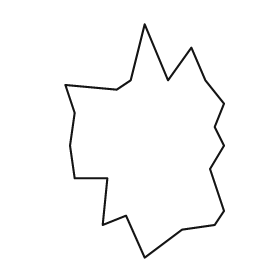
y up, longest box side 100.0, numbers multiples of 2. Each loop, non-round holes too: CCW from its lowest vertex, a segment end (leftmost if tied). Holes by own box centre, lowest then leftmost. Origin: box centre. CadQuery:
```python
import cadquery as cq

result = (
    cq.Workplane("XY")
    .moveTo(0.0, -50.0)
    .lineTo(16.0, -38.0)
    .lineTo(30.0, -36.0)
    .lineTo(34.0, -30.0)
    .lineTo(28.0, -12.0)
    .lineTo(34.0, -2.0)
    .lineTo(30.0, 6.0)
    .lineTo(34.0, 16.0)
    .lineTo(26.0, 26.0)
    .lineTo(20.0, 40.0)
    .lineTo(10.0, 26.0)
    .lineTo(0.0, 50.0)
    .lineTo(-6.0, 26.0)
    .lineTo(-12.0, 22.0)
    .lineTo(-34.0, 24.0)
    .lineTo(-30.0, 12.0)
    .lineTo(-32.0, -2.0)
    .lineTo(-30.0, -16.0)
    .lineTo(-16.0, -16.0)
    .lineTo(-18.0, -36.0)
    .lineTo(-8.0, -32.0)
    .close()
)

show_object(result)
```